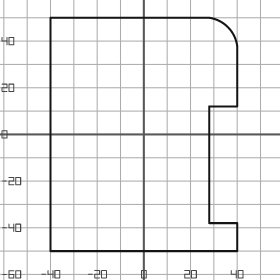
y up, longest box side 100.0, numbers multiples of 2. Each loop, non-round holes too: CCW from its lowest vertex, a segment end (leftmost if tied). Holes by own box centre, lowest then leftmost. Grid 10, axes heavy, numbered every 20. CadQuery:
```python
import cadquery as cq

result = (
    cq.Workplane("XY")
    .moveTo(-40.0, -50.0)
    .lineTo(40.0, -50.0)
    .lineTo(40.0, -38.0)
    .lineTo(28.0, -38.0)
    .lineTo(28.0, 12.0)
    .lineTo(40.0, 12.0)
    .lineTo(40.0, 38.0)
    .threePointArc((36.0, 46.0), (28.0, 50.0))
    .lineTo(-40.0, 50.0)
    .close()
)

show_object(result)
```